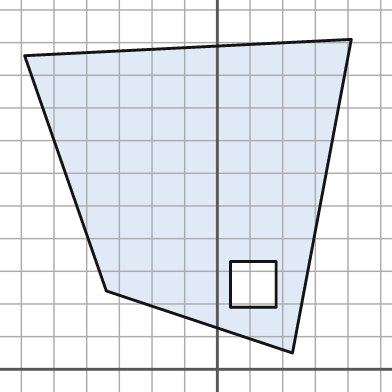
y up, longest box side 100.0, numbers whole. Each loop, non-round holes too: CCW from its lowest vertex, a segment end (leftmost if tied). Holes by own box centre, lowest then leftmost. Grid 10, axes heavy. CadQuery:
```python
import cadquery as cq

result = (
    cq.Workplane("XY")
    .moveTo(23.0, 5.0)
    .lineTo(41.0, 101.0)
    .lineTo(-59.0, 96.0)
    .lineTo(-34.0, 24.0)
    .close()
    .moveTo(4.0, 19.0)
    .lineTo(18.0, 19.0)
    .lineTo(18.0, 33.0)
    .lineTo(4.0, 33.0)
    .close()
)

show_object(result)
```